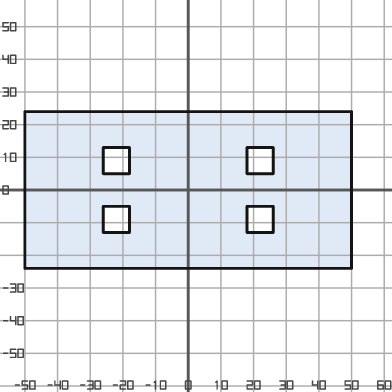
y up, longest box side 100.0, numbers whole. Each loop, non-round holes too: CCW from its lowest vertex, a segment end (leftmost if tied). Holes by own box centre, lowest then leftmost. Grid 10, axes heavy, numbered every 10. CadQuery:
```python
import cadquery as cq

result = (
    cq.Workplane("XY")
    .moveTo(-50.0, -24.0)
    .lineTo(50.0, -24.0)
    .lineTo(50.0, 24.0)
    .lineTo(-50.0, 24.0)
    .close()
    .moveTo(-26.0, -13.0)
    .lineTo(-18.0, -13.0)
    .lineTo(-18.0, -5.0)
    .lineTo(-26.0, -5.0)
    .close()
    .moveTo(18.0, -13.0)
    .lineTo(26.0, -13.0)
    .lineTo(26.0, -5.0)
    .lineTo(18.0, -5.0)
    .close()
    .moveTo(-26.0, 5.0)
    .lineTo(-18.0, 5.0)
    .lineTo(-18.0, 13.0)
    .lineTo(-26.0, 13.0)
    .close()
    .moveTo(18.0, 5.0)
    .lineTo(26.0, 5.0)
    .lineTo(26.0, 13.0)
    .lineTo(18.0, 13.0)
    .close()
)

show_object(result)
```